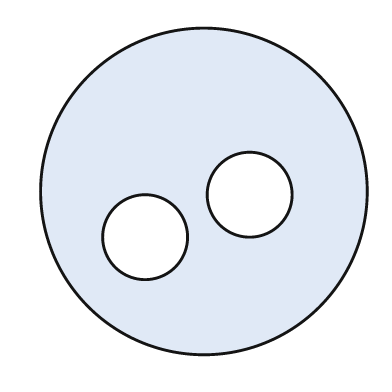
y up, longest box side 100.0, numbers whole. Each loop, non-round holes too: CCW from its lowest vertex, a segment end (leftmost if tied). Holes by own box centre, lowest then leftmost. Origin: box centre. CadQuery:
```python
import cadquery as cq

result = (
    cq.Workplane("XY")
    .moveTo(0.0, 0.0)
    .circle(50.0)
    .moveTo(-18.0, -14.0)
    .circle(13.0)
    .moveTo(14.0, -1.0)
    .circle(13.0)
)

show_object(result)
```